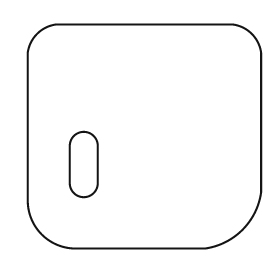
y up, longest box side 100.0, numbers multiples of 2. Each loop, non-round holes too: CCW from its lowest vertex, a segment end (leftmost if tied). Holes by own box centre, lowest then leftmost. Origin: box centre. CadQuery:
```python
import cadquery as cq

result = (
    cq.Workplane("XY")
    .moveTo(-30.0, -48.0)
    .lineTo(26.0, -48.0)
    .threePointArc((42.0, -40.0), (50.0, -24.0))
    .lineTo(50.0, 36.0)
    .threePointArc((46.0, 44.0), (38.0, 48.0))
    .lineTo(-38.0, 48.0)
    .threePointArc((-46.0, 44.0), (-50.0, 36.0))
    .lineTo(-50.0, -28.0)
    .threePointArc((-44.0, -42.0), (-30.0, -48.0))
    .close()
    .moveTo(-32.0, -20.0)
    .threePointArc((-26.0, -26.0), (-20.0, -20.0))
    .lineTo(-20.0, -4.0)
    .threePointArc((-26.0, 2.0), (-32.0, -4.0))
    .close()
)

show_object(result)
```